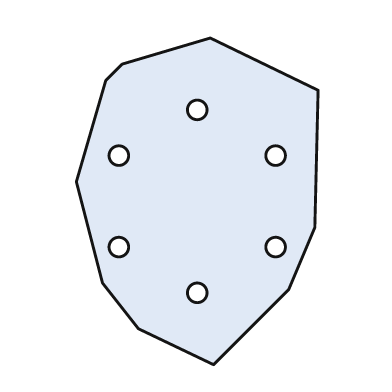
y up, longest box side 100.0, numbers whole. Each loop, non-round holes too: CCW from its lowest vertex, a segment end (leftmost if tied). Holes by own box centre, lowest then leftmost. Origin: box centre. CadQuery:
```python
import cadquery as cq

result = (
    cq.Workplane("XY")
    .moveTo(5.0, -50.0)
    .lineTo(28.0, -27.0)
    .lineTo(36.0, -8.0)
    .lineTo(37.0, 34.0)
    .lineTo(4.0, 50.0)
    .lineTo(-23.0, 42.0)
    .lineTo(-28.0, 37.0)
    .lineTo(-37.0, 6.0)
    .lineTo(-29.0, -25.0)
    .lineTo(-18.0, -39.0)
    .close()
    .moveTo(0.0, -28.0)
    .circle(3.0)
    .moveTo(-24.0, -14.0)
    .circle(3.0)
    .moveTo(24.0, -14.0)
    .circle(3.0)
    .moveTo(-24.0, 14.0)
    .circle(3.0)
    .moveTo(24.0, 14.0)
    .circle(3.0)
    .moveTo(0.0, 28.0)
    .circle(3.0)
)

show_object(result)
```